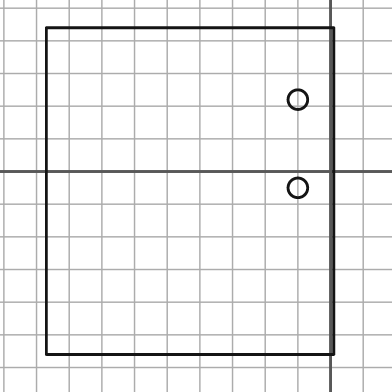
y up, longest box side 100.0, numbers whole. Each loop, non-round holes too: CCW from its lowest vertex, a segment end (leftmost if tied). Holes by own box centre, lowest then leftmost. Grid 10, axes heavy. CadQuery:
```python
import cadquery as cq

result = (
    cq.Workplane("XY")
    .moveTo(-87.0, -56.0)
    .lineTo(1.0, -56.0)
    .lineTo(1.0, 44.0)
    .lineTo(-87.0, 44.0)
    .close()
    .moveTo(-10.0, -5.0)
    .circle(3.0)
    .moveTo(-10.0, 22.0)
    .circle(3.0)
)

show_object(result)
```